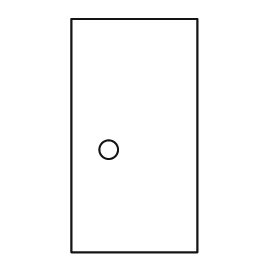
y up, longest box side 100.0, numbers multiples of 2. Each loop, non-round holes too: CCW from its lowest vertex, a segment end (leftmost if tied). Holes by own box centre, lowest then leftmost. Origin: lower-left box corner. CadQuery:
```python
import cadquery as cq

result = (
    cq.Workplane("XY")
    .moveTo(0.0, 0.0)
    .lineTo(54.0, 0.0)
    .lineTo(54.0, 100.0)
    .lineTo(0.0, 100.0)
    .close()
    .moveTo(16.0, 44.0)
    .circle(4.0)
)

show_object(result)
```